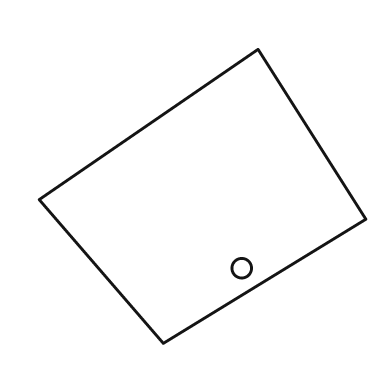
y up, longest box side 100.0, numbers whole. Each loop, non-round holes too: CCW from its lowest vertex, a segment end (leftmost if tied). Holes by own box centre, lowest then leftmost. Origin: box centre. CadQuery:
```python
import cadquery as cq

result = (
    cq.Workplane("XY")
    .moveTo(-12.0, -45.0)
    .lineTo(50.0, -7.0)
    .lineTo(17.0, 45.0)
    .lineTo(-50.0, -1.0)
    .close()
    .moveTo(12.0, -22.0)
    .circle(3.0)
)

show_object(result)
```